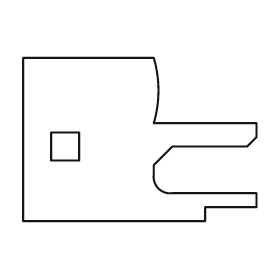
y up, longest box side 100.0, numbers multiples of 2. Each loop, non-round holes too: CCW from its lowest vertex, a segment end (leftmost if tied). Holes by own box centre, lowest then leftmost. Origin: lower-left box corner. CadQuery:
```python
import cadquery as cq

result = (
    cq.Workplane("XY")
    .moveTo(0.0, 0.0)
    .lineTo(78.0, 0.0)
    .lineTo(78.0, 6.0)
    .lineTo(100.0, 6.0)
    .lineTo(100.0, 12.0)
    .lineTo(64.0, 12.0)
    .threePointArc((58.0, 14.0), (56.0, 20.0))
    .lineTo(56.0, 24.0)
    .lineTo(64.0, 32.0)
    .lineTo(96.0, 32.0)
    .lineTo(100.0, 36.0)
    .lineTo(100.0, 42.0)
    .lineTo(56.0, 42.0)
    .threePointArc((58.0, 56.0), (56.0, 70.0))
    .lineTo(0.0, 70.0)
    .close()
    .moveTo(12.0, 26.0)
    .lineTo(24.0, 26.0)
    .lineTo(24.0, 38.0)
    .lineTo(12.0, 38.0)
    .close()
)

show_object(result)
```